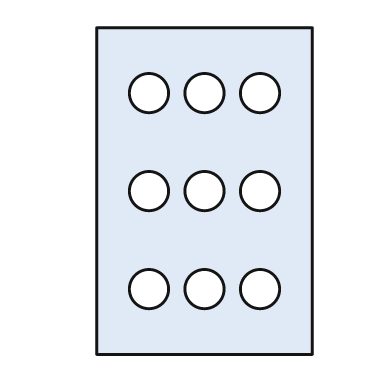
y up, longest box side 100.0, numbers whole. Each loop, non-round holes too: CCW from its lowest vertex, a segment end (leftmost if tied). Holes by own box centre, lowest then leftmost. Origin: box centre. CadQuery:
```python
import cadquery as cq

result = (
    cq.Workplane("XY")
    .moveTo(-33.0, -50.0)
    .lineTo(33.0, -50.0)
    .lineTo(33.0, 50.0)
    .lineTo(-33.0, 50.0)
    .close()
    .moveTo(-17.0, -30.0)
    .circle(6.0)
    .moveTo(0.0, -30.0)
    .circle(6.0)
    .moveTo(17.0, -30.0)
    .circle(6.0)
    .moveTo(-17.0, 0.0)
    .circle(6.0)
    .moveTo(0.0, 0.0)
    .circle(6.0)
    .moveTo(17.0, 0.0)
    .circle(6.0)
    .moveTo(-17.0, 30.0)
    .circle(6.0)
    .moveTo(0.0, 30.0)
    .circle(6.0)
    .moveTo(17.0, 30.0)
    .circle(6.0)
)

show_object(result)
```